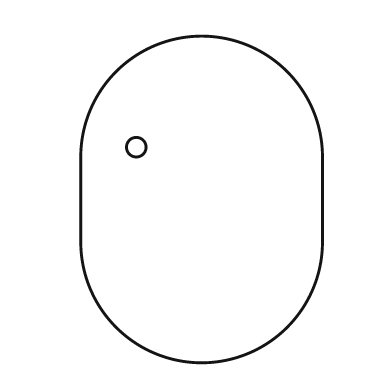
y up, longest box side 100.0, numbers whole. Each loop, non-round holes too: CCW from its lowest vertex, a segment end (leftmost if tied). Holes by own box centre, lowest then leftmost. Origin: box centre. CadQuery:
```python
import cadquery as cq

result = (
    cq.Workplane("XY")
    .moveTo(-37.0, -13.0)
    .threePointArc((0.0, -50.0), (37.0, -13.0))
    .lineTo(37.0, 13.0)
    .threePointArc((0.0, 50.0), (-37.0, 13.0))
    .close()
    .moveTo(-20.0, 16.0)
    .circle(3.0)
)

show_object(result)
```